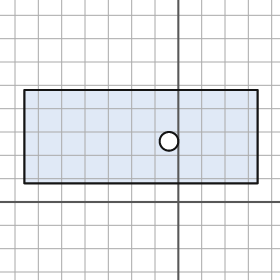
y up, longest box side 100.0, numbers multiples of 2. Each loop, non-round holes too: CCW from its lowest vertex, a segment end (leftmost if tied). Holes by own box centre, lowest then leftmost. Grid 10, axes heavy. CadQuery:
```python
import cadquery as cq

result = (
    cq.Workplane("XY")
    .moveTo(-66.0, 8.0)
    .lineTo(34.0, 8.0)
    .lineTo(34.0, 48.0)
    .lineTo(-66.0, 48.0)
    .close()
    .moveTo(-4.0, 26.0)
    .circle(4.0)
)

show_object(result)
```